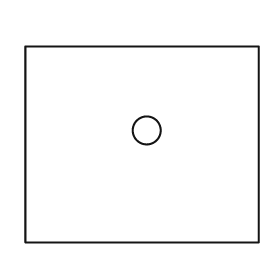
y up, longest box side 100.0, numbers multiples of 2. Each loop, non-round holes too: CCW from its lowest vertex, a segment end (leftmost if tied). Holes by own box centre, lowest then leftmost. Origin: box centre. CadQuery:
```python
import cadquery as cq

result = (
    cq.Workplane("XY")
    .moveTo(-50.0, -42.0)
    .lineTo(50.0, -42.0)
    .lineTo(50.0, 42.0)
    .lineTo(-50.0, 42.0)
    .close()
    .moveTo(2.0, 6.0)
    .circle(6.0)
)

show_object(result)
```